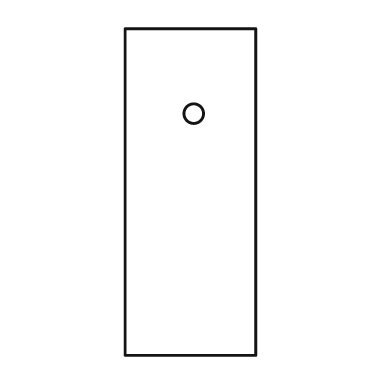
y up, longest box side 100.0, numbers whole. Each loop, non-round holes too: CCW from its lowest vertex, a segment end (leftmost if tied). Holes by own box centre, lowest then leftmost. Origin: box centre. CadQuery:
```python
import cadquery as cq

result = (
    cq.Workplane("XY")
    .moveTo(-20.0, -50.0)
    .lineTo(20.0, -50.0)
    .lineTo(20.0, 50.0)
    .lineTo(-20.0, 50.0)
    .close()
    .moveTo(1.0, 24.0)
    .circle(3.0)
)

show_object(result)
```